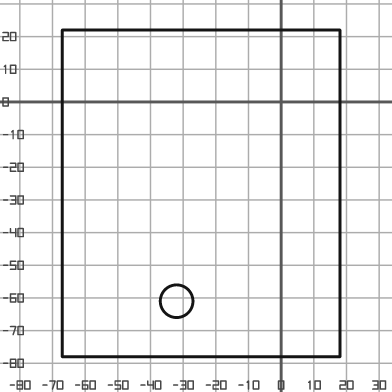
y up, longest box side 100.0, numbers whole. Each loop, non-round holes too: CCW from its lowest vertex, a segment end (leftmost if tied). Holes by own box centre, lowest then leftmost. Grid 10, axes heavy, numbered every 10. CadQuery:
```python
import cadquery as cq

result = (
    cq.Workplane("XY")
    .moveTo(-67.0, -78.0)
    .lineTo(18.0, -78.0)
    .lineTo(18.0, 22.0)
    .lineTo(-67.0, 22.0)
    .close()
    .moveTo(-32.0, -61.0)
    .circle(5.0)
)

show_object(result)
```